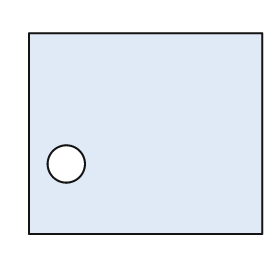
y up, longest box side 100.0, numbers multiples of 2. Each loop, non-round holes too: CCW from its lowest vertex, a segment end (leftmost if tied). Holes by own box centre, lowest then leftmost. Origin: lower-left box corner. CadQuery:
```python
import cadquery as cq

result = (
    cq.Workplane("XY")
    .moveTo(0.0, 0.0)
    .lineTo(100.0, 0.0)
    .lineTo(100.0, 86.0)
    .lineTo(0.0, 86.0)
    .close()
    .moveTo(16.0, 30.0)
    .circle(8.0)
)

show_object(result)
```